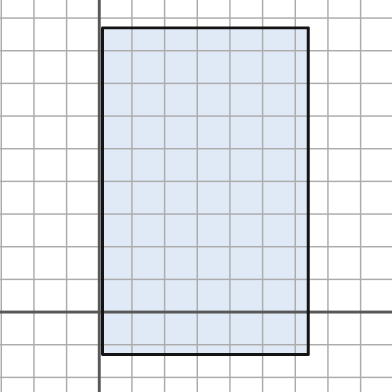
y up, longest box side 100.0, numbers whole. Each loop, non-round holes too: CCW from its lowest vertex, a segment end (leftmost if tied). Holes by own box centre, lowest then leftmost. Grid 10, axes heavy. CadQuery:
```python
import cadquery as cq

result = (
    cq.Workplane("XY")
    .moveTo(1.0, -13.0)
    .lineTo(64.0, -13.0)
    .lineTo(64.0, 87.0)
    .lineTo(1.0, 87.0)
    .close()
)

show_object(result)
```